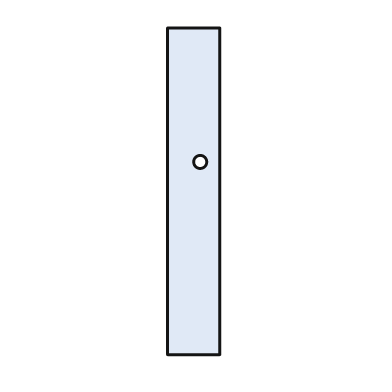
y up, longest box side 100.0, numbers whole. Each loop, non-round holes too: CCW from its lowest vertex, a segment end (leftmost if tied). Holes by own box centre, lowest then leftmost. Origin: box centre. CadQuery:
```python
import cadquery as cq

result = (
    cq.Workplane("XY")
    .moveTo(-8.0, -50.0)
    .lineTo(8.0, -50.0)
    .lineTo(8.0, 50.0)
    .lineTo(-8.0, 50.0)
    .close()
    .moveTo(2.0, 9.0)
    .circle(2.0)
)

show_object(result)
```